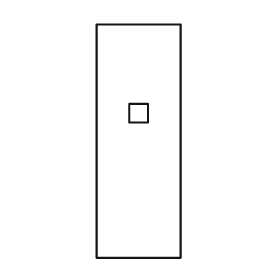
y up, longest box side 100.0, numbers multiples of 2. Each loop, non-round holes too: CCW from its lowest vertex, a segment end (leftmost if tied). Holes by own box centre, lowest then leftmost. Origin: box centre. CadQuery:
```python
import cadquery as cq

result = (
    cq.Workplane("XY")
    .moveTo(-18.0, -50.0)
    .lineTo(18.0, -50.0)
    .lineTo(18.0, 50.0)
    .lineTo(-18.0, 50.0)
    .close()
    .moveTo(-4.0, 8.0)
    .lineTo(4.0, 8.0)
    .lineTo(4.0, 16.0)
    .lineTo(-4.0, 16.0)
    .close()
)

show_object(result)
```